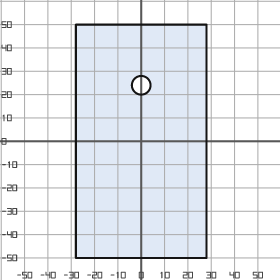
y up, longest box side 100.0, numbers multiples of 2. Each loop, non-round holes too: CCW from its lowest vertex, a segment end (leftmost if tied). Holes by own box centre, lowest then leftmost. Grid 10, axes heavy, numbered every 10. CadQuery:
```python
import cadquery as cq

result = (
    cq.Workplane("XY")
    .moveTo(-28.0, -50.0)
    .lineTo(28.0, -50.0)
    .lineTo(28.0, 50.0)
    .lineTo(-28.0, 50.0)
    .close()
    .moveTo(0.0, 24.0)
    .circle(4.0)
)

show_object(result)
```